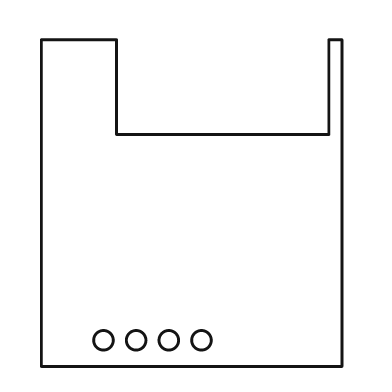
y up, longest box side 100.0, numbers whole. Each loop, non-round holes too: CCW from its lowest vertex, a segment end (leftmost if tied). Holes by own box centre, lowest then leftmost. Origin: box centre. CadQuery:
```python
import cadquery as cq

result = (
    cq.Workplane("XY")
    .moveTo(-46.0, -50.0)
    .lineTo(46.0, -50.0)
    .lineTo(46.0, 50.0)
    .lineTo(42.0, 50.0)
    .lineTo(42.0, 21.0)
    .lineTo(-23.0, 21.0)
    .lineTo(-23.0, 50.0)
    .lineTo(-46.0, 50.0)
    .close()
    .moveTo(-27.0, -42.0)
    .circle(3.0)
    .moveTo(-17.0, -42.0)
    .circle(3.0)
    .moveTo(-7.0, -42.0)
    .circle(3.0)
    .moveTo(3.0, -42.0)
    .circle(3.0)
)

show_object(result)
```